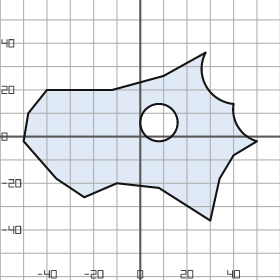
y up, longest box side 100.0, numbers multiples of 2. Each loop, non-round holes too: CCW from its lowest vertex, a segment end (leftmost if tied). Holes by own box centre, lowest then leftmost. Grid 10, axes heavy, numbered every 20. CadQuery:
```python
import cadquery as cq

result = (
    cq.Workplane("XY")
    .moveTo(30.0, -36.0)
    .lineTo(34.0, -18.0)
    .lineTo(40.0, -8.0)
    .lineTo(50.0, -2.0)
    .threePointArc((42.0, 4.0), (40.0, 14.0))
    .threePointArc((28.0, 22.0), (28.0, 36.0))
    .lineTo(10.0, 26.0)
    .lineTo(-12.0, 20.0)
    .lineTo(-40.0, 20.0)
    .lineTo(-48.0, 10.0)
    .lineTo(-50.0, -2.0)
    .lineTo(-36.0, -18.0)
    .lineTo(-24.0, -26.0)
    .lineTo(-10.0, -20.0)
    .lineTo(8.0, -22.0)
    .close()
    .moveTo(8.0, 6.0)
    .circle(8.0)
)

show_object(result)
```